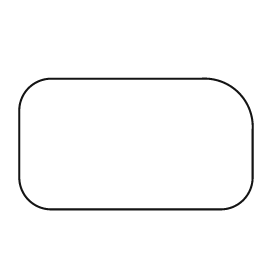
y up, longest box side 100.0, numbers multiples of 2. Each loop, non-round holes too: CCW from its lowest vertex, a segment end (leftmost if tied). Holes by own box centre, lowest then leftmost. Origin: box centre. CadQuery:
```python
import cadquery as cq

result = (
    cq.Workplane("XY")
    .moveTo(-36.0, -28.0)
    .lineTo(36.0, -28.0)
    .threePointArc((46.0, -24.0), (50.0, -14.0))
    .lineTo(50.0, 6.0)
    .threePointArc((44.0, 22.0), (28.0, 28.0))
    .lineTo(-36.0, 28.0)
    .threePointArc((-46.0, 24.0), (-50.0, 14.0))
    .lineTo(-50.0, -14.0)
    .threePointArc((-46.0, -24.0), (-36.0, -28.0))
    .close()
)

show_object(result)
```